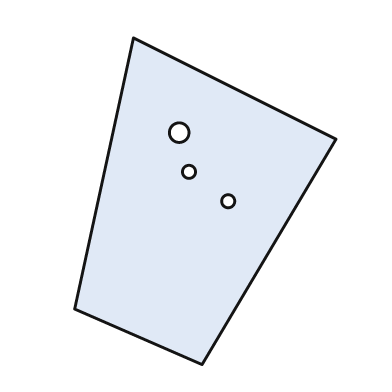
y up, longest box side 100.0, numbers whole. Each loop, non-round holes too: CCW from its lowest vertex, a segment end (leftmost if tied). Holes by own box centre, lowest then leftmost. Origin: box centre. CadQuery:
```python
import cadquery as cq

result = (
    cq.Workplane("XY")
    .moveTo(-1.0, -50.0)
    .lineTo(40.0, 19.0)
    .lineTo(-22.0, 50.0)
    .lineTo(-40.0, -33.0)
    .close()
    .moveTo(7.0, 0.0)
    .circle(2.0)
    .moveTo(-5.0, 9.0)
    .circle(2.0)
    .moveTo(-8.0, 21.0)
    .circle(3.0)
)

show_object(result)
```